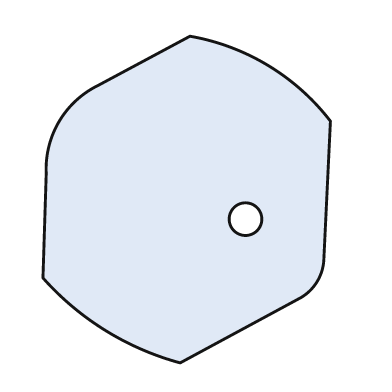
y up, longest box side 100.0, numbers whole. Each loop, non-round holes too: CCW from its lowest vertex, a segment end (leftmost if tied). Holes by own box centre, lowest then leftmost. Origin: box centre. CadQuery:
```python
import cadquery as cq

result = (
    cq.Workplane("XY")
    .moveTo(-2.0, -50.0)
    .lineTo(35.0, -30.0)
    .threePointArc((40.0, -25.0), (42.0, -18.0))
    .lineTo(44.0, 24.0)
    .threePointArc((25.0, 41.0), (1.0, 50.0))
    .lineTo(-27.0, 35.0)
    .threePointArc((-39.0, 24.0), (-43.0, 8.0))
    .lineTo(-44.0, -24.0)
    .threePointArc((-25.0, -40.0), (-2.0, -50.0))
    .close()
    .moveTo(18.0, -6.0)
    .circle(5.0)
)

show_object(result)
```